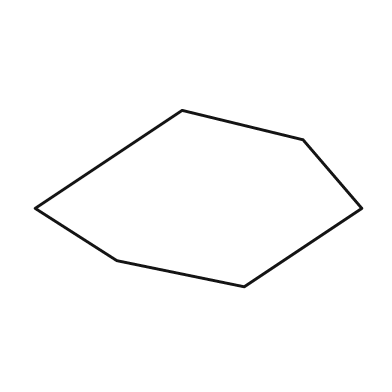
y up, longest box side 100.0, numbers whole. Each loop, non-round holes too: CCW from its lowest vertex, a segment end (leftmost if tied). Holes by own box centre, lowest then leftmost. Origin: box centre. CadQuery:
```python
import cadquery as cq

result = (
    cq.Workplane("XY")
    .moveTo(14.0, -27.0)
    .lineTo(50.0, -3.0)
    .lineTo(32.0, 18.0)
    .lineTo(-5.0, 27.0)
    .lineTo(-50.0, -3.0)
    .lineTo(-25.0, -19.0)
    .close()
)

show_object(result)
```